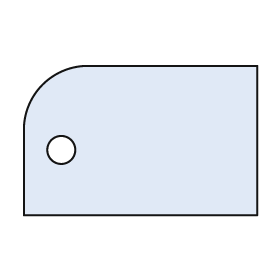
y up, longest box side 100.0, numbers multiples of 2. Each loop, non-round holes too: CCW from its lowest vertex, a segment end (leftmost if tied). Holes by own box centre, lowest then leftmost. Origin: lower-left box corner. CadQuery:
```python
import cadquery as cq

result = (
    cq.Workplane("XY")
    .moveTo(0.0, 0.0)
    .lineTo(100.0, 0.0)
    .lineTo(100.0, 64.0)
    .lineTo(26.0, 64.0)
    .threePointArc((8.0, 56.0), (0.0, 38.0))
    .close()
    .moveTo(16.0, 28.0)
    .circle(6.0)
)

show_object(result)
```